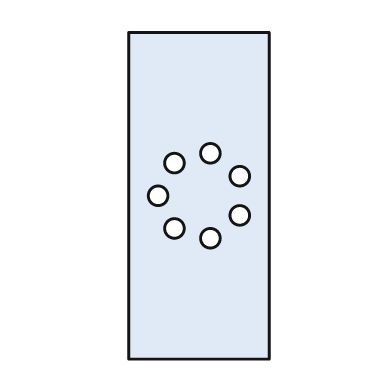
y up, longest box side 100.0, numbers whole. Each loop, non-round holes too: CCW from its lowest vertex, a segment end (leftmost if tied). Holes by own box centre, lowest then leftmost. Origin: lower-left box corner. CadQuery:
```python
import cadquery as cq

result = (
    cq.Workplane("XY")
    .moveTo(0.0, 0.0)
    .lineTo(43.0, 0.0)
    .lineTo(43.0, 100.0)
    .lineTo(0.0, 100.0)
    .close()
    .moveTo(25.0, 37.0)
    .circle(3.0)
    .moveTo(14.0, 40.0)
    .circle(3.0)
    .moveTo(34.0, 44.0)
    .circle(3.0)
    .moveTo(9.0, 50.0)
    .circle(3.0)
    .moveTo(34.0, 56.0)
    .circle(3.0)
    .moveTo(14.0, 60.0)
    .circle(3.0)
    .moveTo(25.0, 63.0)
    .circle(3.0)
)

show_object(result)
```